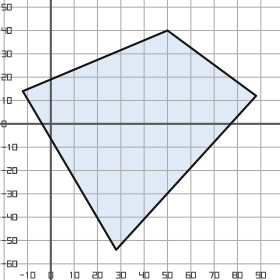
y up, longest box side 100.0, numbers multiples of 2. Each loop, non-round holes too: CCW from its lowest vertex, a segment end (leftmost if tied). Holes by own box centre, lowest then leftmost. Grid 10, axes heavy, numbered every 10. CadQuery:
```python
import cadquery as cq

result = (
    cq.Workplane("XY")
    .moveTo(28.0, -54.0)
    .lineTo(88.0, 12.0)
    .lineTo(50.0, 40.0)
    .lineTo(-12.0, 14.0)
    .close()
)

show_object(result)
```